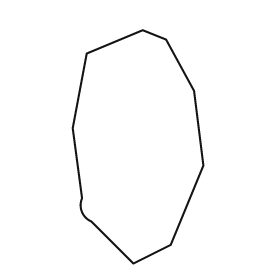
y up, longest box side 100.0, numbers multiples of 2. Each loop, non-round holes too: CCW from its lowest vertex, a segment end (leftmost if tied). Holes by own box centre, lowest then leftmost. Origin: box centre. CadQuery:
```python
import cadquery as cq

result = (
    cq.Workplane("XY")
    .moveTo(-2.0, -50.0)
    .lineTo(14.0, -42.0)
    .lineTo(28.0, -8.0)
    .lineTo(24.0, 24.0)
    .lineTo(12.0, 46.0)
    .lineTo(2.0, 50.0)
    .lineTo(-22.0, 40.0)
    .lineTo(-28.0, 8.0)
    .lineTo(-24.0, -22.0)
    .threePointArc((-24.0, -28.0), (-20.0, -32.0))
    .close()
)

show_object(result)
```